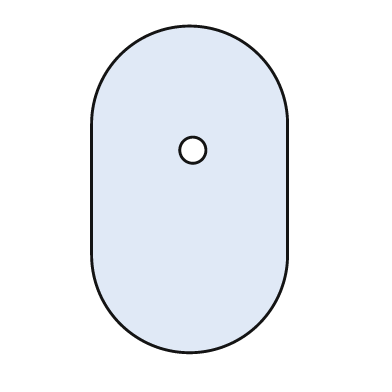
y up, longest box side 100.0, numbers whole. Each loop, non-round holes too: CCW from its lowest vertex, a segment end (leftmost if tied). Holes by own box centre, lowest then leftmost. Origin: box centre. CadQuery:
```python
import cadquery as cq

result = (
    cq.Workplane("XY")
    .moveTo(-30.0, -20.0)
    .threePointArc((0.0, -50.0), (30.0, -20.0))
    .lineTo(30.0, 20.0)
    .threePointArc((0.0, 50.0), (-30.0, 20.0))
    .close()
    .moveTo(1.0, 12.0)
    .circle(4.0)
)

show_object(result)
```